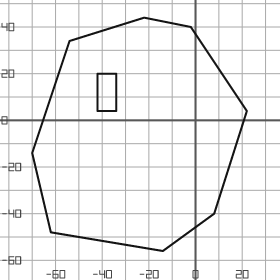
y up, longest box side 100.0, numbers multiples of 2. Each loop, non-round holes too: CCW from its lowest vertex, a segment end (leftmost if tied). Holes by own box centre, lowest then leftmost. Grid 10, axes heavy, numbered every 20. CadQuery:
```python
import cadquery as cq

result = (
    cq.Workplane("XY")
    .moveTo(-14.0, -56.0)
    .lineTo(8.0, -40.0)
    .lineTo(22.0, 4.0)
    .lineTo(-2.0, 40.0)
    .lineTo(-22.0, 44.0)
    .lineTo(-54.0, 34.0)
    .lineTo(-70.0, -14.0)
    .lineTo(-62.0, -48.0)
    .close()
    .moveTo(-42.0, 4.0)
    .lineTo(-34.0, 4.0)
    .lineTo(-34.0, 20.0)
    .lineTo(-42.0, 20.0)
    .close()
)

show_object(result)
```